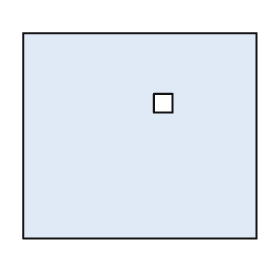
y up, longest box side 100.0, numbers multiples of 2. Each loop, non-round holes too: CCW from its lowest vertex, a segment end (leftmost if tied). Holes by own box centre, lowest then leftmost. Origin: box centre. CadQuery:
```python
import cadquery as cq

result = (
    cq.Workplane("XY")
    .moveTo(-50.0, -44.0)
    .lineTo(50.0, -44.0)
    .lineTo(50.0, 44.0)
    .lineTo(-50.0, 44.0)
    .close()
    .moveTo(6.0, 10.0)
    .lineTo(14.0, 10.0)
    .lineTo(14.0, 18.0)
    .lineTo(6.0, 18.0)
    .close()
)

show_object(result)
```